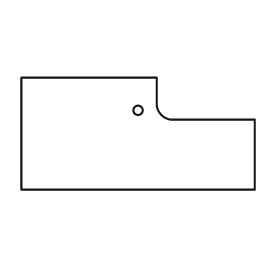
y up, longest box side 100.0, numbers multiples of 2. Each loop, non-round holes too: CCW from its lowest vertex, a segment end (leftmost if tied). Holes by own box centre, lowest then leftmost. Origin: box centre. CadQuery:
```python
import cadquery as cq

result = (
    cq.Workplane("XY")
    .moveTo(-50.0, -24.0)
    .lineTo(50.0, -24.0)
    .lineTo(50.0, 6.0)
    .lineTo(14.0, 6.0)
    .threePointArc((10.0, 8.0), (8.0, 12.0))
    .lineTo(8.0, 24.0)
    .lineTo(-50.0, 24.0)
    .close()
    .moveTo(0.0, 10.0)
    .circle(2.0)
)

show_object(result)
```